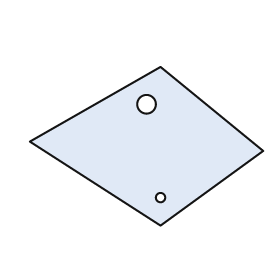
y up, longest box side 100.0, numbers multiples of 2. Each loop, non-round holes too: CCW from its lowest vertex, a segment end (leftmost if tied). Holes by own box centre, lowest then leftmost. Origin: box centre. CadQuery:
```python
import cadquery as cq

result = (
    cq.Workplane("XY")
    .moveTo(6.0, -34.0)
    .lineTo(50.0, -2.0)
    .lineTo(6.0, 34.0)
    .lineTo(-50.0, 2.0)
    .close()
    .moveTo(6.0, -22.0)
    .circle(2.0)
    .moveTo(0.0, 18.0)
    .circle(4.0)
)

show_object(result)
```